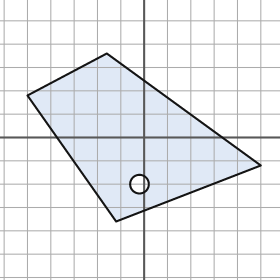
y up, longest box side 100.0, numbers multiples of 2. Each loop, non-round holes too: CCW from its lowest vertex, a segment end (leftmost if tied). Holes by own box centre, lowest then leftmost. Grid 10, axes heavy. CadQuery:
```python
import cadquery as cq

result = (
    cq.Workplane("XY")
    .moveTo(-12.0, -36.0)
    .lineTo(50.0, -12.0)
    .lineTo(-16.0, 36.0)
    .lineTo(-50.0, 18.0)
    .close()
    .moveTo(-2.0, -20.0)
    .circle(4.0)
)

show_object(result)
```